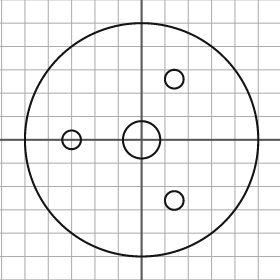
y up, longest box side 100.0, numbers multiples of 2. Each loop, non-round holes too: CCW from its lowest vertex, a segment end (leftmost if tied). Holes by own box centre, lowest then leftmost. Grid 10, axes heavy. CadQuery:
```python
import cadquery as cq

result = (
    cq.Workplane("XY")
    .moveTo(0.0, 0.0)
    .circle(50.0)
    .moveTo(14.0, -26.0)
    .circle(4.0)
    .moveTo(-30.0, 0.0)
    .circle(4.0)
    .moveTo(0.0, 0.0)
    .circle(8.0)
    .moveTo(14.0, 26.0)
    .circle(4.0)
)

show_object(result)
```